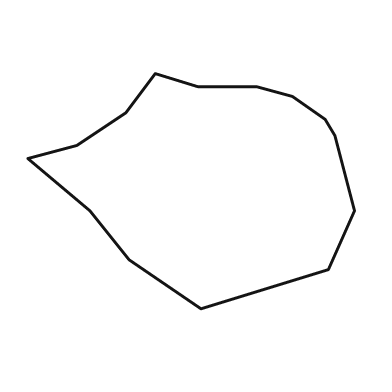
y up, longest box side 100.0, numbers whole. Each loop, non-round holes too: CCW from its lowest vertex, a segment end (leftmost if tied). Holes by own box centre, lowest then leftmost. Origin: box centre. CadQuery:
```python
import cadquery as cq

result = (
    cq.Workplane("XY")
    .moveTo(3.0, -36.0)
    .lineTo(42.0, -24.0)
    .lineTo(50.0, -6.0)
    .lineTo(44.0, 17.0)
    .lineTo(41.0, 22.0)
    .lineTo(31.0, 29.0)
    .lineTo(20.0, 32.0)
    .lineTo(2.0, 32.0)
    .lineTo(-11.0, 36.0)
    .lineTo(-20.0, 24.0)
    .lineTo(-35.0, 14.0)
    .lineTo(-50.0, 10.0)
    .lineTo(-31.0, -6.0)
    .lineTo(-19.0, -21.0)
    .close()
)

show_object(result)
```